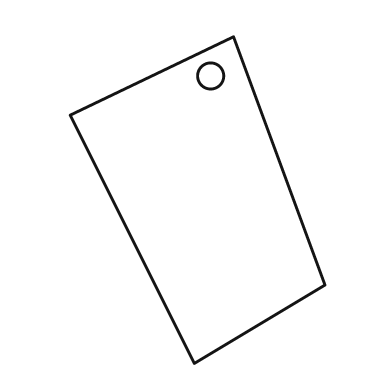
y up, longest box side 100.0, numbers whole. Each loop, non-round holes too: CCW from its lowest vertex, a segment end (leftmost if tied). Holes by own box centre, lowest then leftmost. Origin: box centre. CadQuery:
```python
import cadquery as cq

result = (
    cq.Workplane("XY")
    .moveTo(-1.0, -50.0)
    .lineTo(39.0, -26.0)
    .lineTo(11.0, 50.0)
    .lineTo(-39.0, 26.0)
    .close()
    .moveTo(4.0, 38.0)
    .circle(4.0)
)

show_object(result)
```